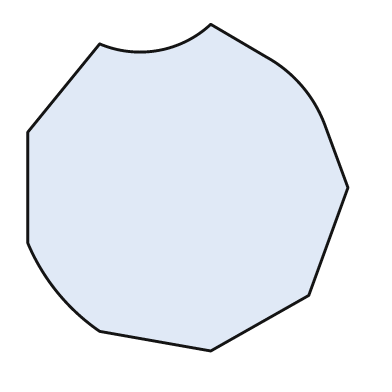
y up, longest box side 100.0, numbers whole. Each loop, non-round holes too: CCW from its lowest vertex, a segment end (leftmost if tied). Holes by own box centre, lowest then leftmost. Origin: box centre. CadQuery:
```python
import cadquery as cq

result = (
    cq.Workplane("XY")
    .moveTo(7.0, -50.0)
    .lineTo(37.0, -33.0)
    .lineTo(49.0, 0.0)
    .lineTo(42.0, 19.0)
    .threePointArc((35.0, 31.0), (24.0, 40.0))
    .lineTo(7.0, 50.0)
    .threePointArc((-9.0, 42.0), (-27.0, 44.0))
    .lineTo(-49.0, 17.0)
    .lineTo(-49.0, -17.0)
    .threePointArc((-40.0, -32.0), (-27.0, -44.0))
    .close()
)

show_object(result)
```